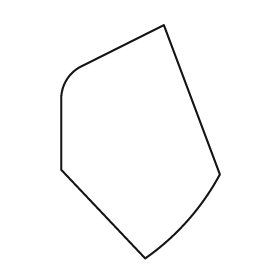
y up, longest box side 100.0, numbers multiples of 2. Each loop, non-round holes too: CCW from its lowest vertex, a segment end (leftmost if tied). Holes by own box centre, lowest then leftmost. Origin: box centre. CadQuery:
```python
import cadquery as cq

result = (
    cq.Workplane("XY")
    .moveTo(2.0, -50.0)
    .threePointArc((20.0, -34.0), (34.0, -14.0))
    .lineTo(10.0, 50.0)
    .lineTo(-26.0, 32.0)
    .threePointArc((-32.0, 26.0), (-34.0, 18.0))
    .lineTo(-34.0, -12.0)
    .close()
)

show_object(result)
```